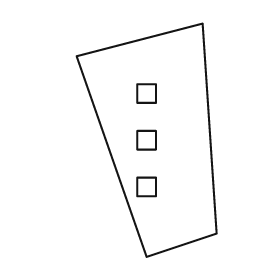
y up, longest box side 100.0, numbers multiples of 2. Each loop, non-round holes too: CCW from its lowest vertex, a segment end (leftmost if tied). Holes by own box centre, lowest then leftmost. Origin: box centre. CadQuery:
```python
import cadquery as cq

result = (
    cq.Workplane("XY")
    .moveTo(0.0, -50.0)
    .lineTo(30.0, -40.0)
    .lineTo(24.0, 50.0)
    .lineTo(-30.0, 36.0)
    .close()
    .moveTo(-4.0, -24.0)
    .lineTo(4.0, -24.0)
    .lineTo(4.0, -16.0)
    .lineTo(-4.0, -16.0)
    .close()
    .moveTo(-4.0, -4.0)
    .lineTo(4.0, -4.0)
    .lineTo(4.0, 4.0)
    .lineTo(-4.0, 4.0)
    .close()
    .moveTo(-4.0, 16.0)
    .lineTo(4.0, 16.0)
    .lineTo(4.0, 24.0)
    .lineTo(-4.0, 24.0)
    .close()
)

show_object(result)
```